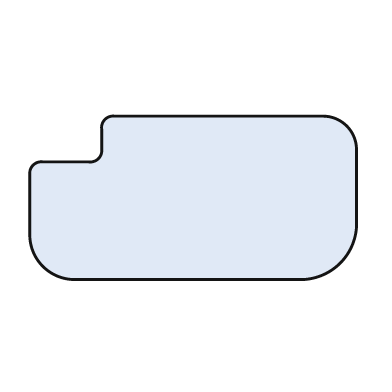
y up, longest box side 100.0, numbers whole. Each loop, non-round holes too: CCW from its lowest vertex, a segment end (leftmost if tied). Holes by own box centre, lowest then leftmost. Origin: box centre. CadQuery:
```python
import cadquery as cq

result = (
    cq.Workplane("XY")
    .moveTo(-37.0, -25.0)
    .lineTo(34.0, -25.0)
    .threePointArc((45.0, -20.0), (50.0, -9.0))
    .lineTo(50.0, 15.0)
    .threePointArc((47.0, 22.0), (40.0, 25.0))
    .lineTo(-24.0, 25.0)
    .threePointArc((-27.0, 24.0), (-28.0, 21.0))
    .lineTo(-28.0, 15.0)
    .threePointArc((-29.0, 12.0), (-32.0, 11.0))
    .lineTo(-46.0, 11.0)
    .threePointArc((-49.0, 10.0), (-50.0, 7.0))
    .lineTo(-50.0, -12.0)
    .threePointArc((-46.0, -21.0), (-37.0, -25.0))
    .close()
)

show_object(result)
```